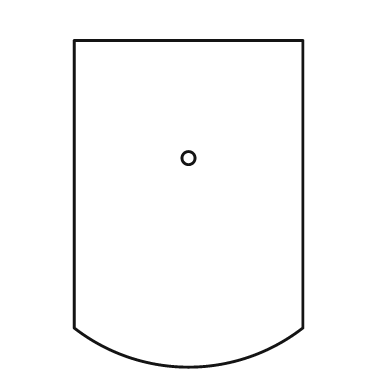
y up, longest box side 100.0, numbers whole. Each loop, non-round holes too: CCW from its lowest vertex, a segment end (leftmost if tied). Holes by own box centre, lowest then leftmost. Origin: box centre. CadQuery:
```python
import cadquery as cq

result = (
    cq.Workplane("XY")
    .moveTo(-35.0, -38.0)
    .threePointArc((0.0, -50.0), (35.0, -38.0))
    .lineTo(35.0, 50.0)
    .lineTo(-35.0, 50.0)
    .close()
    .moveTo(0.0, 14.0)
    .circle(2.0)
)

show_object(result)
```